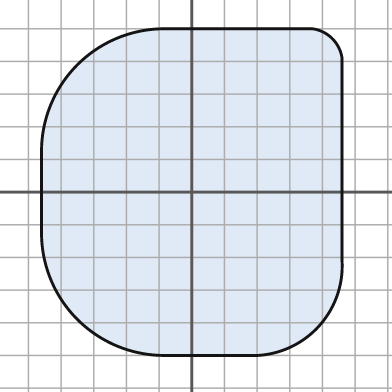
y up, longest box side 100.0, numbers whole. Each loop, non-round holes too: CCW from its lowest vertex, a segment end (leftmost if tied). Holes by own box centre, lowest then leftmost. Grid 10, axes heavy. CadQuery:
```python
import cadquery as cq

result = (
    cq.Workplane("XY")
    .moveTo(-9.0, -50.0)
    .lineTo(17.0, -50.0)
    .threePointArc((38.0, -42.0), (46.0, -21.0))
    .lineTo(46.0, 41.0)
    .threePointArc((43.0, 47.0), (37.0, 50.0))
    .lineTo(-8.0, 50.0)
    .threePointArc((-35.0, 39.0), (-46.0, 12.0))
    .lineTo(-46.0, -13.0)
    .threePointArc((-35.0, -39.0), (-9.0, -50.0))
    .close()
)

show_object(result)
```